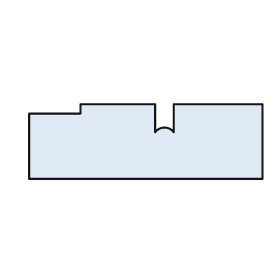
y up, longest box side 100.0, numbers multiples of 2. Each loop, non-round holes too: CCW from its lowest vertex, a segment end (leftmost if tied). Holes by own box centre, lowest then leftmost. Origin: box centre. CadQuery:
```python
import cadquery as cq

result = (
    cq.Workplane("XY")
    .moveTo(-50.0, -16.0)
    .lineTo(50.0, -16.0)
    .lineTo(50.0, 16.0)
    .lineTo(12.0, 16.0)
    .lineTo(12.0, 4.0)
    .threePointArc((8.0, 6.0), (4.0, 4.0))
    .lineTo(4.0, 16.0)
    .lineTo(-28.0, 16.0)
    .lineTo(-28.0, 12.0)
    .lineTo(-50.0, 12.0)
    .close()
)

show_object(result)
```